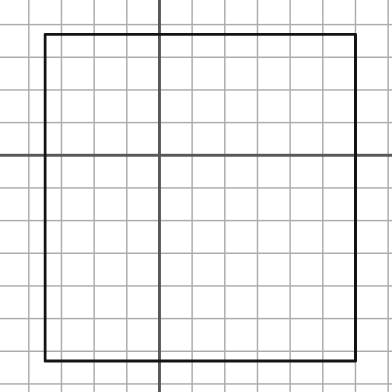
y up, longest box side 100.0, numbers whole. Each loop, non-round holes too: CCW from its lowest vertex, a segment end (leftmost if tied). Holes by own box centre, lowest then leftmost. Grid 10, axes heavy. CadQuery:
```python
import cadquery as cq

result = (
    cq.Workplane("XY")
    .moveTo(-35.0, -63.0)
    .lineTo(60.0, -63.0)
    .lineTo(60.0, 37.0)
    .lineTo(-35.0, 37.0)
    .close()
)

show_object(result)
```